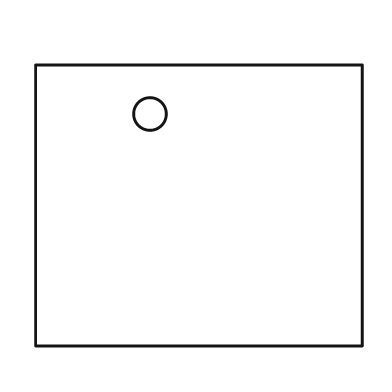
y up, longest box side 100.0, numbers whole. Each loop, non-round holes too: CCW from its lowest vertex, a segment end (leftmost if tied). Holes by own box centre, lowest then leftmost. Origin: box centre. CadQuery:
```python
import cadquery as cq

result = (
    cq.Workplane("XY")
    .moveTo(-50.0, -43.0)
    .lineTo(50.0, -43.0)
    .lineTo(50.0, 43.0)
    .lineTo(-50.0, 43.0)
    .close()
    .moveTo(-15.0, 28.0)
    .circle(5.0)
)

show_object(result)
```